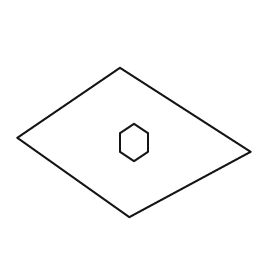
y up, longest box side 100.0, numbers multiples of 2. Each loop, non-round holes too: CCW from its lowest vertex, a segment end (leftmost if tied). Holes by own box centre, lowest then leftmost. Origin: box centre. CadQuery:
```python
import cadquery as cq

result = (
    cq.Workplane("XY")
    .moveTo(-2.0, -32.0)
    .lineTo(50.0, -4.0)
    .lineTo(-6.0, 32.0)
    .lineTo(-50.0, 2.0)
    .close()
    .moveTo(0.0, -8.0)
    .lineTo(6.0, -4.0)
    .lineTo(6.0, 4.0)
    .lineTo(0.0, 8.0)
    .lineTo(-6.0, 4.0)
    .lineTo(-6.0, -4.0)
    .close()
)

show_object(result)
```